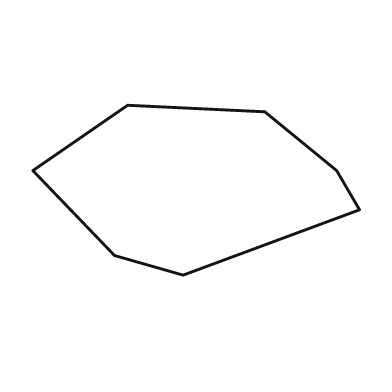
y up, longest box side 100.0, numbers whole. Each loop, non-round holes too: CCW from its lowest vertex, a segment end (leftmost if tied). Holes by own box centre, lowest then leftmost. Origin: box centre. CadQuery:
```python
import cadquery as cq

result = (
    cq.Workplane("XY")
    .moveTo(-4.0, -26.0)
    .lineTo(50.0, -6.0)
    .lineTo(43.0, 6.0)
    .lineTo(21.0, 24.0)
    .lineTo(-21.0, 26.0)
    .lineTo(-50.0, 6.0)
    .lineTo(-25.0, -20.0)
    .close()
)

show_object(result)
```